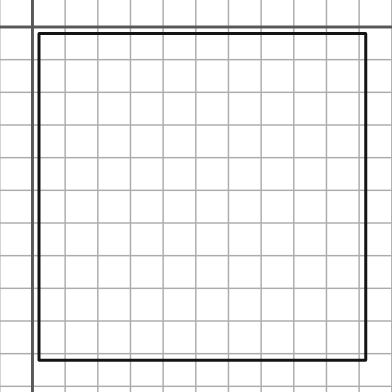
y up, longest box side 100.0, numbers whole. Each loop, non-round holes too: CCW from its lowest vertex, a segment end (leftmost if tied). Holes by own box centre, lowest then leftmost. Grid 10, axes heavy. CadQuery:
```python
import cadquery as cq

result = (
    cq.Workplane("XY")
    .moveTo(2.0, -102.0)
    .lineTo(102.0, -102.0)
    .lineTo(102.0, -2.0)
    .lineTo(2.0, -2.0)
    .close()
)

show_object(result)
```